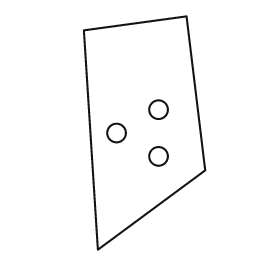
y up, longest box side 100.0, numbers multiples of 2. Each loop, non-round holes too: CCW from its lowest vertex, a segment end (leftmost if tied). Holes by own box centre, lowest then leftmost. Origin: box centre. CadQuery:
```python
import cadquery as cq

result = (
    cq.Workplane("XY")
    .moveTo(-20.0, -50.0)
    .lineTo(26.0, -16.0)
    .lineTo(18.0, 50.0)
    .lineTo(-26.0, 44.0)
    .close()
    .moveTo(6.0, -10.0)
    .circle(4.0)
    .moveTo(-12.0, 0.0)
    .circle(4.0)
    .moveTo(6.0, 10.0)
    .circle(4.0)
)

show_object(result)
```